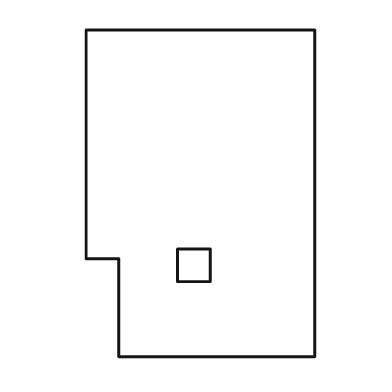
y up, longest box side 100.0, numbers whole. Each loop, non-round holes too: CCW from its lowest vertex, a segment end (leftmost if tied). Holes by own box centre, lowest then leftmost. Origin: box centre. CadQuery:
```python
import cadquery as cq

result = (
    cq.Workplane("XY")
    .moveTo(-25.0, -50.0)
    .lineTo(35.0, -50.0)
    .lineTo(35.0, 50.0)
    .lineTo(-35.0, 50.0)
    .lineTo(-35.0, -20.0)
    .lineTo(-25.0, -20.0)
    .close()
    .moveTo(-7.0, -27.0)
    .lineTo(3.0, -27.0)
    .lineTo(3.0, -17.0)
    .lineTo(-7.0, -17.0)
    .close()
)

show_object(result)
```